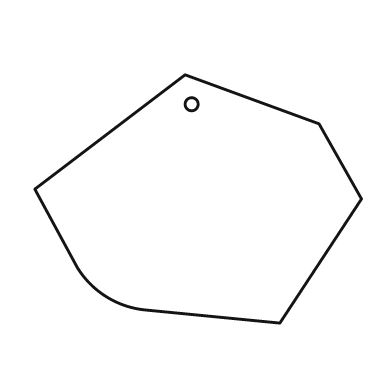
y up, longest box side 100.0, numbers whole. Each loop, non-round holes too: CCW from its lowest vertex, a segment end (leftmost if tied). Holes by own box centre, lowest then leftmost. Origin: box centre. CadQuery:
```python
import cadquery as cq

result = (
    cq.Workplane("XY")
    .moveTo(25.0, -38.0)
    .lineTo(50.0, 0.0)
    .lineTo(37.0, 23.0)
    .lineTo(-4.0, 38.0)
    .lineTo(-50.0, 3.0)
    .lineTo(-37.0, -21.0)
    .threePointArc((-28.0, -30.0), (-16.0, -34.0))
    .close()
    .moveTo(-2.0, 29.0)
    .circle(2.0)
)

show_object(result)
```